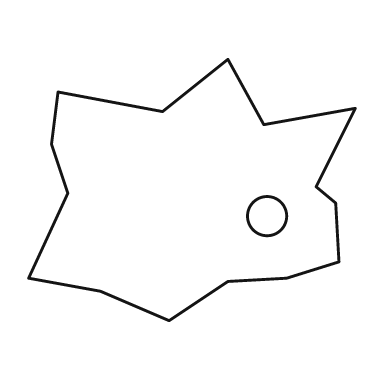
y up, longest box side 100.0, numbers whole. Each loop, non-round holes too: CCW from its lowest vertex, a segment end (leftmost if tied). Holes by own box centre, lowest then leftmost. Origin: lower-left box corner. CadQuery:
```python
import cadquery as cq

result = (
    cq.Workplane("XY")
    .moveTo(43.0, 0.0)
    .lineTo(61.0, 12.0)
    .lineTo(79.0, 13.0)
    .lineTo(95.0, 18.0)
    .lineTo(94.0, 36.0)
    .lineTo(88.0, 41.0)
    .lineTo(100.0, 65.0)
    .lineTo(72.0, 60.0)
    .lineTo(61.0, 80.0)
    .lineTo(41.0, 64.0)
    .lineTo(9.0, 70.0)
    .lineTo(7.0, 54.0)
    .lineTo(12.0, 39.0)
    .lineTo(0.0, 13.0)
    .lineTo(22.0, 9.0)
    .close()
    .moveTo(73.0, 32.0)
    .circle(6.0)
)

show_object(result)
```